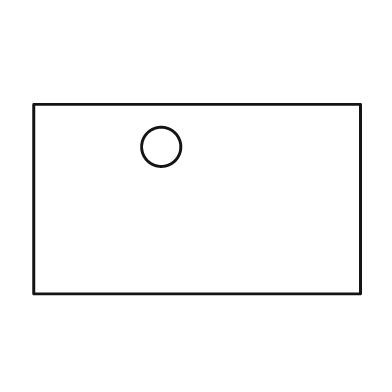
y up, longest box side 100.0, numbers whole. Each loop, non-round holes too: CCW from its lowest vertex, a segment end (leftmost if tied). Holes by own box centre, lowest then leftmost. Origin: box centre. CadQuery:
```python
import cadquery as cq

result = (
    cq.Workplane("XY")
    .moveTo(-50.0, -29.0)
    .lineTo(50.0, -29.0)
    .lineTo(50.0, 29.0)
    .lineTo(-50.0, 29.0)
    .close()
    .moveTo(-11.0, 16.0)
    .circle(6.0)
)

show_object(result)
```